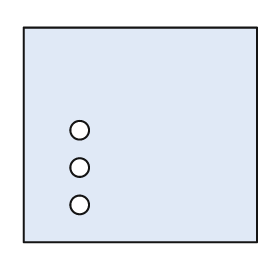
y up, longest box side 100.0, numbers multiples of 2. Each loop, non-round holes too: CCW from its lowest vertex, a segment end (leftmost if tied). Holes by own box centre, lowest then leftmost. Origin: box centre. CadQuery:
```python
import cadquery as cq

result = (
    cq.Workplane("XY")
    .moveTo(-50.0, -46.0)
    .lineTo(50.0, -46.0)
    .lineTo(50.0, 46.0)
    .lineTo(-50.0, 46.0)
    .close()
    .moveTo(-26.0, -30.0)
    .circle(4.0)
    .moveTo(-26.0, -14.0)
    .circle(4.0)
    .moveTo(-26.0, 2.0)
    .circle(4.0)
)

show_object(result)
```